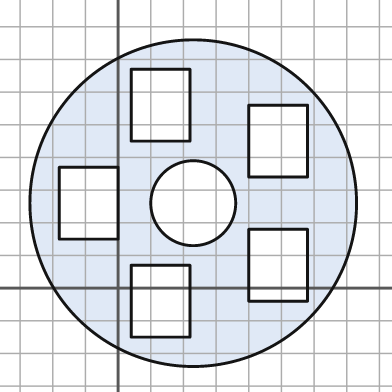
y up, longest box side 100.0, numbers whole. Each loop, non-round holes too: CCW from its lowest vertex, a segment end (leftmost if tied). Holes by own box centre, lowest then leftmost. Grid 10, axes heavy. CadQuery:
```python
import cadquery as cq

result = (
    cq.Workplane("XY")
    .moveTo(23.0, 26.0)
    .circle(50.0)
    .moveTo(4.0, -15.0)
    .lineTo(22.0, -15.0)
    .lineTo(22.0, 7.0)
    .lineTo(4.0, 7.0)
    .close()
    .moveTo(40.0, -4.0)
    .lineTo(58.0, -4.0)
    .lineTo(58.0, 18.0)
    .lineTo(40.0, 18.0)
    .close()
    .moveTo(-18.0, 15.0)
    .lineTo(0.0, 15.0)
    .lineTo(0.0, 37.0)
    .lineTo(-18.0, 37.0)
    .close()
    .moveTo(23.0, 26.0)
    .circle(13.0)
    .moveTo(40.0, 34.0)
    .lineTo(58.0, 34.0)
    .lineTo(58.0, 56.0)
    .lineTo(40.0, 56.0)
    .close()
    .moveTo(4.0, 45.0)
    .lineTo(22.0, 45.0)
    .lineTo(22.0, 67.0)
    .lineTo(4.0, 67.0)
    .close()
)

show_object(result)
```